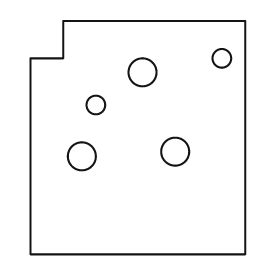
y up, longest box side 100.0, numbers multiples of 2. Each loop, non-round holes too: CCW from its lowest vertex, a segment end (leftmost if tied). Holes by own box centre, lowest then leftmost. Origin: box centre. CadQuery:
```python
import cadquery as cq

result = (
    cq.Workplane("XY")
    .moveTo(-46.0, -50.0)
    .lineTo(46.0, -50.0)
    .lineTo(46.0, 50.0)
    .lineTo(-32.0, 50.0)
    .lineTo(-32.0, 34.0)
    .lineTo(-46.0, 34.0)
    .close()
    .moveTo(-24.0, -8.0)
    .circle(6.0)
    .moveTo(16.0, -6.0)
    .circle(6.0)
    .moveTo(-18.0, 14.0)
    .circle(4.0)
    .moveTo(2.0, 28.0)
    .circle(6.0)
    .moveTo(36.0, 34.0)
    .circle(4.0)
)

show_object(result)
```